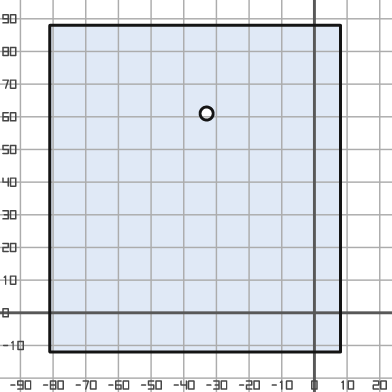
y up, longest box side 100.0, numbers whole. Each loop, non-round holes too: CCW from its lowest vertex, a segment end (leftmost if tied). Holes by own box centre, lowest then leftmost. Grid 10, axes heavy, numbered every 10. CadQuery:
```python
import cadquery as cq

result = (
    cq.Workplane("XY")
    .moveTo(-81.0, -12.0)
    .lineTo(8.0, -12.0)
    .lineTo(8.0, 88.0)
    .lineTo(-81.0, 88.0)
    .close()
    .moveTo(-33.0, 61.0)
    .circle(2.0)
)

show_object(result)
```